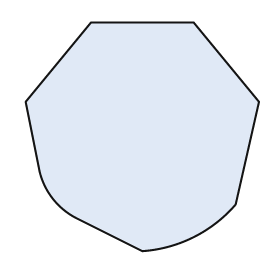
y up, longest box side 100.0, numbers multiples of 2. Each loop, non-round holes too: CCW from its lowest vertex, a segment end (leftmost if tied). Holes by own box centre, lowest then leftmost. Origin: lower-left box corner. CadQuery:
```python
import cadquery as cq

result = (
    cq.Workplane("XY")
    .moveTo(50.0, 0.0)
    .threePointArc((72.0, 6.0), (90.0, 20.0))
    .lineTo(100.0, 64.0)
    .lineTo(72.0, 98.0)
    .lineTo(28.0, 98.0)
    .lineTo(0.0, 64.0)
    .lineTo(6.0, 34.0)
    .threePointArc((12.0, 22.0), (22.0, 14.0))
    .close()
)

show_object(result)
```